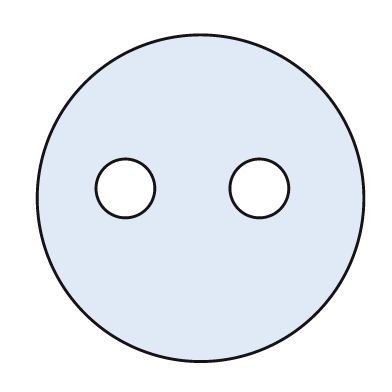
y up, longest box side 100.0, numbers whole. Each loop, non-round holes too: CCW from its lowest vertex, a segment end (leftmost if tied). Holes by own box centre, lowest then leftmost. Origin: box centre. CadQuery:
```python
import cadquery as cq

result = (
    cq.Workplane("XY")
    .moveTo(0.0, 0.0)
    .circle(50.0)
    .moveTo(-23.0, 3.0)
    .circle(9.0)
    .moveTo(18.0, 3.0)
    .circle(9.0)
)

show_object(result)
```